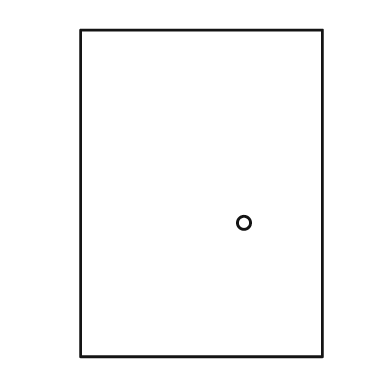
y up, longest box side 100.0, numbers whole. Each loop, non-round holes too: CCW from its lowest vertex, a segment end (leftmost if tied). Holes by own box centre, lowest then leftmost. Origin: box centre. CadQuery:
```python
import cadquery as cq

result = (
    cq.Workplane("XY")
    .moveTo(-37.0, -50.0)
    .lineTo(37.0, -50.0)
    .lineTo(37.0, 50.0)
    .lineTo(-37.0, 50.0)
    .close()
    .moveTo(13.0, -9.0)
    .circle(2.0)
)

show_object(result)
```